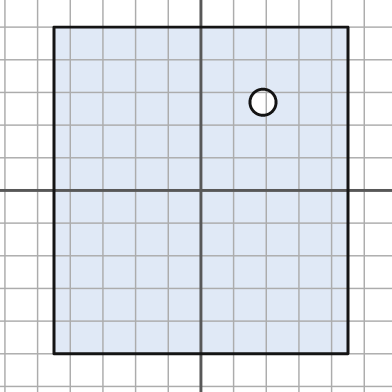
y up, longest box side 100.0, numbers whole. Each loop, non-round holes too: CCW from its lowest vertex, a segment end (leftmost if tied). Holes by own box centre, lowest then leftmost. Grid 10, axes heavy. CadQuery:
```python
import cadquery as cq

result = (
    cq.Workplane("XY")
    .moveTo(-45.0, -50.0)
    .lineTo(45.0, -50.0)
    .lineTo(45.0, 50.0)
    .lineTo(-45.0, 50.0)
    .close()
    .moveTo(19.0, 27.0)
    .circle(4.0)
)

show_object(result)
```